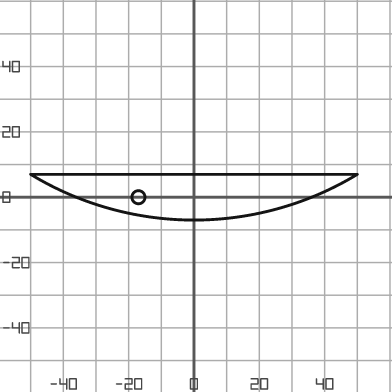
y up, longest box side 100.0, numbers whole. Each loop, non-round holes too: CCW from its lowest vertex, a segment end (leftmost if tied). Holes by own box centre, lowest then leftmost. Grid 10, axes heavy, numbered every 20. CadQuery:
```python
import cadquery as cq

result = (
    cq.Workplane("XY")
    .moveTo(-50.0, 7.0)
    .threePointArc((0.0, -7.0), (50.0, 7.0))
    .close()
    .moveTo(-17.0, 0.0)
    .circle(2.0)
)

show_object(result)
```